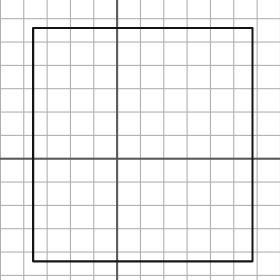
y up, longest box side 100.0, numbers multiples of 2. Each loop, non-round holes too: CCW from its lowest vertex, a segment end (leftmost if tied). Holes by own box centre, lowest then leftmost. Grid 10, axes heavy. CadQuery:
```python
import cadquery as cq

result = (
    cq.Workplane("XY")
    .moveTo(-36.0, -44.0)
    .lineTo(58.0, -44.0)
    .lineTo(58.0, 56.0)
    .lineTo(-36.0, 56.0)
    .close()
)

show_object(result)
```